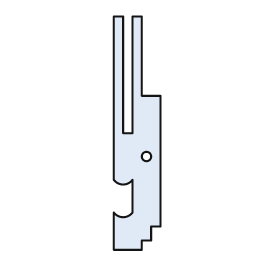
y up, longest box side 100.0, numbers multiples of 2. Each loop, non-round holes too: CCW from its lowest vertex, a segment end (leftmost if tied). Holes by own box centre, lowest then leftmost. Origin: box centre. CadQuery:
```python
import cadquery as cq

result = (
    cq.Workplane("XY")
    .moveTo(-10.0, -50.0)
    .lineTo(2.0, -50.0)
    .lineTo(2.0, -46.0)
    .lineTo(6.0, -46.0)
    .lineTo(6.0, -40.0)
    .lineTo(10.0, -40.0)
    .lineTo(10.0, 16.0)
    .lineTo(2.0, 16.0)
    .lineTo(2.0, 50.0)
    .lineTo(-2.0, 50.0)
    .lineTo(-2.0, 0.0)
    .lineTo(-6.0, 0.0)
    .lineTo(-6.0, 50.0)
    .lineTo(-10.0, 50.0)
    .lineTo(-10.0, -20.0)
    .threePointArc((-6.0, -22.0), (-2.0, -20.0))
    .lineTo(-2.0, -34.0)
    .threePointArc((-6.0, -36.0), (-10.0, -34.0))
    .close()
    .moveTo(4.0, -10.0)
    .circle(2.0)
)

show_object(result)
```